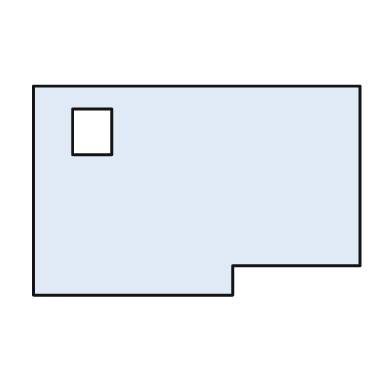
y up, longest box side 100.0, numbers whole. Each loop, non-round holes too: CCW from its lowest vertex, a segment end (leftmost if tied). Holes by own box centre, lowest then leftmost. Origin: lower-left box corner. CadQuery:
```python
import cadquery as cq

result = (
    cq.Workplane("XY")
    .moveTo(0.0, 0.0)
    .lineTo(61.0, 0.0)
    .lineTo(61.0, 9.0)
    .lineTo(100.0, 9.0)
    .lineTo(100.0, 64.0)
    .lineTo(0.0, 64.0)
    .close()
    .moveTo(12.0, 43.0)
    .lineTo(24.0, 43.0)
    .lineTo(24.0, 57.0)
    .lineTo(12.0, 57.0)
    .close()
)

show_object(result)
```